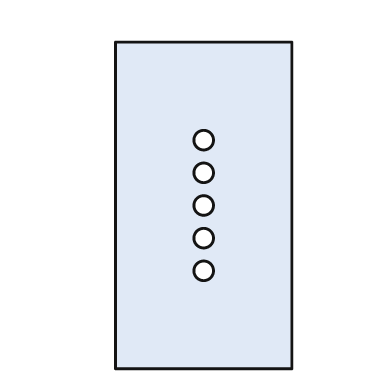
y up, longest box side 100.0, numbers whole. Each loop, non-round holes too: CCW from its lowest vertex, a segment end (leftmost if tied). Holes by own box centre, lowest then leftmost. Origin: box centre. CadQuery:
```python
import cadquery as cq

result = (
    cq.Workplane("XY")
    .moveTo(-27.0, -50.0)
    .lineTo(27.0, -50.0)
    .lineTo(27.0, 50.0)
    .lineTo(-27.0, 50.0)
    .close()
    .moveTo(0.0, -20.0)
    .circle(3.0)
    .moveTo(0.0, -10.0)
    .circle(3.0)
    .moveTo(0.0, 0.0)
    .circle(3.0)
    .moveTo(0.0, 10.0)
    .circle(3.0)
    .moveTo(0.0, 20.0)
    .circle(3.0)
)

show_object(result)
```